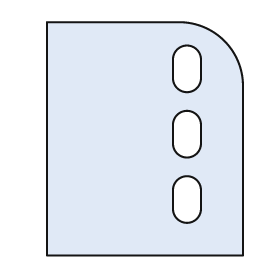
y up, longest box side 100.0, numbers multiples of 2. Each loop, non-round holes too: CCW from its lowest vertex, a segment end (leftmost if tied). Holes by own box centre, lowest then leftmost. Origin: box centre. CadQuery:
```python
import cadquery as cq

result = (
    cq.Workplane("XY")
    .moveTo(-42.0, -50.0)
    .lineTo(42.0, -50.0)
    .lineTo(42.0, 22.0)
    .threePointArc((34.0, 42.0), (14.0, 50.0))
    .lineTo(-42.0, 50.0)
    .close()
    .moveTo(12.0, -30.0)
    .threePointArc((18.0, -36.0), (24.0, -30.0))
    .lineTo(24.0, -22.0)
    .threePointArc((18.0, -16.0), (12.0, -22.0))
    .close()
    .moveTo(12.0, -2.0)
    .threePointArc((18.0, -8.0), (24.0, -2.0))
    .lineTo(24.0, 6.0)
    .threePointArc((18.0, 12.0), (12.0, 6.0))
    .close()
    .moveTo(12.0, 26.0)
    .threePointArc((18.0, 20.0), (24.0, 26.0))
    .lineTo(24.0, 34.0)
    .threePointArc((18.0, 40.0), (12.0, 34.0))
    .close()
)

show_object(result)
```